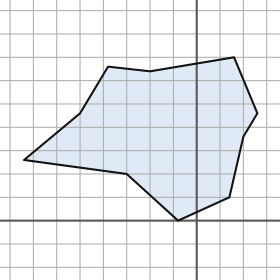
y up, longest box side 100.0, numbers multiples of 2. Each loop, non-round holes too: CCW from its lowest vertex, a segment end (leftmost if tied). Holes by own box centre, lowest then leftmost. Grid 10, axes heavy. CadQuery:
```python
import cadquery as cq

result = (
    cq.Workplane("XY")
    .moveTo(-8.0, 0.0)
    .lineTo(14.0, 10.0)
    .lineTo(20.0, 36.0)
    .lineTo(26.0, 46.0)
    .lineTo(16.0, 70.0)
    .lineTo(-20.0, 64.0)
    .lineTo(-38.0, 66.0)
    .lineTo(-50.0, 46.0)
    .lineTo(-74.0, 26.0)
    .lineTo(-30.0, 20.0)
    .close()
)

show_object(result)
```